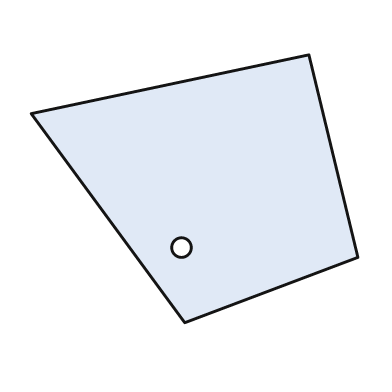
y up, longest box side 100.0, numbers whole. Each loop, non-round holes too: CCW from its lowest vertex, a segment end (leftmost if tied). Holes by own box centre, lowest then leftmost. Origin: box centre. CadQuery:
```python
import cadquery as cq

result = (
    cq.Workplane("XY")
    .moveTo(-3.0, -41.0)
    .lineTo(50.0, -21.0)
    .lineTo(35.0, 41.0)
    .lineTo(-50.0, 23.0)
    .close()
    .moveTo(-4.0, -18.0)
    .circle(3.0)
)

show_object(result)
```